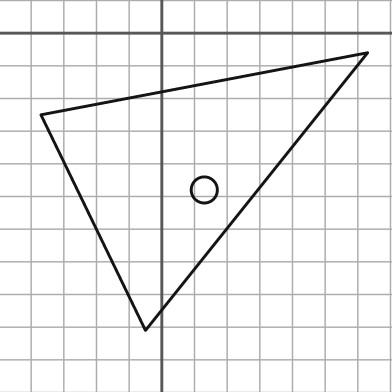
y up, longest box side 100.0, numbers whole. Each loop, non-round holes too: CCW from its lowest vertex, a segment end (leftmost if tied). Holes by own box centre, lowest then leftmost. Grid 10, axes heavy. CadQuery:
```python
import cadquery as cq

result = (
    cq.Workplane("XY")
    .moveTo(-5.0, -91.0)
    .lineTo(63.0, -6.0)
    .lineTo(-37.0, -25.0)
    .close()
    .moveTo(13.0, -48.0)
    .circle(4.0)
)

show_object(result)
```